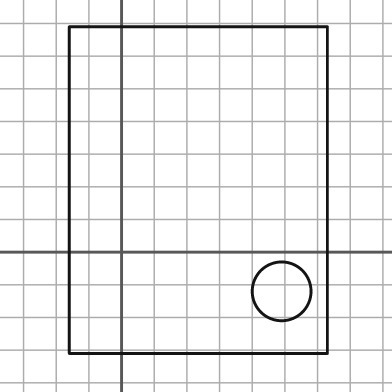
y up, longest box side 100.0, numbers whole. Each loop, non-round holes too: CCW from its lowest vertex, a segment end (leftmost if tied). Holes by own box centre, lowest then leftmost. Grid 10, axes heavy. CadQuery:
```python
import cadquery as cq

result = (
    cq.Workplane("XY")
    .moveTo(-16.0, -31.0)
    .lineTo(63.0, -31.0)
    .lineTo(63.0, 69.0)
    .lineTo(-16.0, 69.0)
    .close()
    .moveTo(49.0, -12.0)
    .circle(9.0)
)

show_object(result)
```